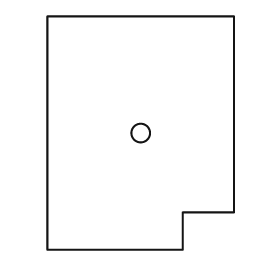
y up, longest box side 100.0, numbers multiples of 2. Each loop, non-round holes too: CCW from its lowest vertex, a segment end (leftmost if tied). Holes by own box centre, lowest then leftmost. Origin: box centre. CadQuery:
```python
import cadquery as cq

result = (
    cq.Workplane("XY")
    .moveTo(-40.0, -50.0)
    .lineTo(18.0, -50.0)
    .lineTo(18.0, -34.0)
    .lineTo(40.0, -34.0)
    .lineTo(40.0, 50.0)
    .lineTo(-40.0, 50.0)
    .close()
    .moveTo(0.0, 0.0)
    .circle(4.0)
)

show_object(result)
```